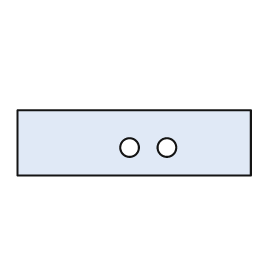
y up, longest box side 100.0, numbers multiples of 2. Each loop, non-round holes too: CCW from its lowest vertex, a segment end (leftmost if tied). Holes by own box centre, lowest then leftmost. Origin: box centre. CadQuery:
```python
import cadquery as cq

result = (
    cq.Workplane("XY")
    .moveTo(-50.0, -14.0)
    .lineTo(50.0, -14.0)
    .lineTo(50.0, 14.0)
    .lineTo(-50.0, 14.0)
    .close()
    .moveTo(-2.0, -2.0)
    .circle(4.0)
    .moveTo(14.0, -2.0)
    .circle(4.0)
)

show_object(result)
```